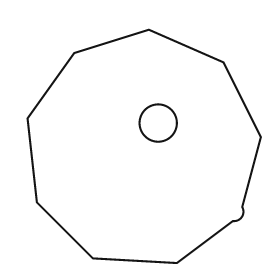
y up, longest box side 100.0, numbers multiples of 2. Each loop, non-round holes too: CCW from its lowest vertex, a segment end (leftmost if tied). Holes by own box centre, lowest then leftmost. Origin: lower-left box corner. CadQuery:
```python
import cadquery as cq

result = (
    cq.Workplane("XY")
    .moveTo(64.0, 0.0)
    .lineTo(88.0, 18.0)
    .threePointArc((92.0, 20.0), (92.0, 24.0))
    .lineTo(100.0, 54.0)
    .lineTo(84.0, 86.0)
    .lineTo(52.0, 100.0)
    .lineTo(20.0, 90.0)
    .lineTo(0.0, 62.0)
    .lineTo(4.0, 26.0)
    .lineTo(28.0, 2.0)
    .close()
    .moveTo(56.0, 60.0)
    .circle(8.0)
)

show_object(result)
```